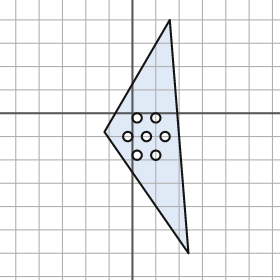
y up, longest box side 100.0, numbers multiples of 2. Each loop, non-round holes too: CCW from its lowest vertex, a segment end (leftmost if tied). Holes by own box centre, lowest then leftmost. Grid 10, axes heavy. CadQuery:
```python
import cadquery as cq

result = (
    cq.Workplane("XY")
    .moveTo(24.0, -60.0)
    .lineTo(16.0, 40.0)
    .lineTo(-12.0, -8.0)
    .close()
    .moveTo(2.0, -18.0)
    .circle(2.0)
    .moveTo(10.0, -18.0)
    .circle(2.0)
    .moveTo(-2.0, -10.0)
    .circle(2.0)
    .moveTo(6.0, -10.0)
    .circle(2.0)
    .moveTo(14.0, -10.0)
    .circle(2.0)
    .moveTo(2.0, -2.0)
    .circle(2.0)
    .moveTo(10.0, -2.0)
    .circle(2.0)
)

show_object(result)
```